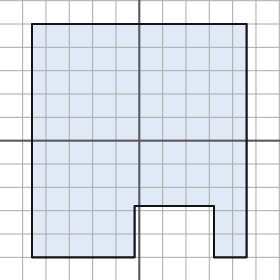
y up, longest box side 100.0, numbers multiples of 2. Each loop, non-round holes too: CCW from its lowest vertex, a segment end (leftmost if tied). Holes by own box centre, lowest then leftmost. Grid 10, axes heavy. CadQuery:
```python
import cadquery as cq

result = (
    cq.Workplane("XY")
    .moveTo(-46.0, -50.0)
    .lineTo(-2.0, -50.0)
    .lineTo(-2.0, -28.0)
    .lineTo(32.0, -28.0)
    .lineTo(32.0, -50.0)
    .lineTo(46.0, -50.0)
    .lineTo(46.0, 50.0)
    .lineTo(-46.0, 50.0)
    .close()
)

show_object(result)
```